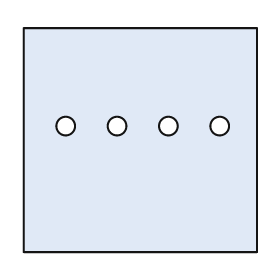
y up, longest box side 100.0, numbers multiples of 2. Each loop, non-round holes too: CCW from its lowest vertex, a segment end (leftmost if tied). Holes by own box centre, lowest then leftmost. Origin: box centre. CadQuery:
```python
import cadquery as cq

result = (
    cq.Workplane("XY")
    .moveTo(-50.0, -48.0)
    .lineTo(50.0, -48.0)
    .lineTo(50.0, 48.0)
    .lineTo(-50.0, 48.0)
    .close()
    .moveTo(-32.0, 6.0)
    .circle(4.0)
    .moveTo(-10.0, 6.0)
    .circle(4.0)
    .moveTo(12.0, 6.0)
    .circle(4.0)
    .moveTo(34.0, 6.0)
    .circle(4.0)
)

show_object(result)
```